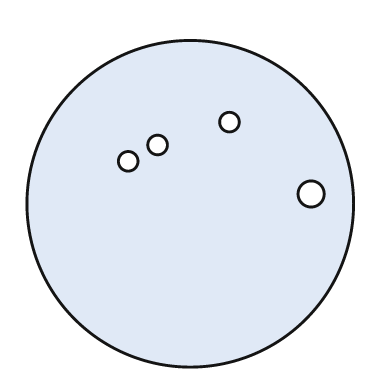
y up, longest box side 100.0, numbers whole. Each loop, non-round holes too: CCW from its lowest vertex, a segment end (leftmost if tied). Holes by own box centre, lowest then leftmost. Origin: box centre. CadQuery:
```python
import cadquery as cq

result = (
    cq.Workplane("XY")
    .moveTo(0.0, 0.0)
    .circle(50.0)
    .moveTo(37.0, 3.0)
    .circle(4.0)
    .moveTo(-19.0, 13.0)
    .circle(3.0)
    .moveTo(-10.0, 18.0)
    .circle(3.0)
    .moveTo(12.0, 25.0)
    .circle(3.0)
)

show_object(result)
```